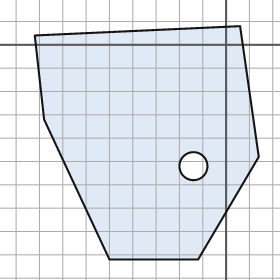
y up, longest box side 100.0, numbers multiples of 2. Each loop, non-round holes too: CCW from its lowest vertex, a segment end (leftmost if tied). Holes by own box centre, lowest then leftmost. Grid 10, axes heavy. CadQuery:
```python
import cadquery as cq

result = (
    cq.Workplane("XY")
    .moveTo(-50.0, -92.0)
    .lineTo(-12.0, -92.0)
    .lineTo(14.0, -48.0)
    .lineTo(6.0, 8.0)
    .lineTo(-82.0, 4.0)
    .lineTo(-78.0, -32.0)
    .close()
    .moveTo(-14.0, -52.0)
    .circle(6.0)
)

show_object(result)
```